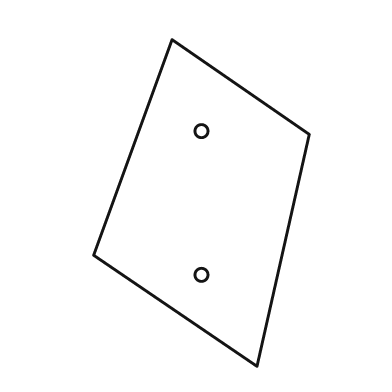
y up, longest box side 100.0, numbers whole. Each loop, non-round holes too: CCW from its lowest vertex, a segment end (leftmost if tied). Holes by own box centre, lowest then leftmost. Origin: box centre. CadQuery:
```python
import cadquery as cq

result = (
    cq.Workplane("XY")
    .moveTo(17.0, -50.0)
    .lineTo(33.0, 21.0)
    .lineTo(-9.0, 50.0)
    .lineTo(-33.0, -16.0)
    .close()
    .moveTo(0.0, -22.0)
    .circle(2.0)
    .moveTo(0.0, 22.0)
    .circle(2.0)
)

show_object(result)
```